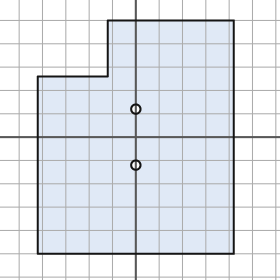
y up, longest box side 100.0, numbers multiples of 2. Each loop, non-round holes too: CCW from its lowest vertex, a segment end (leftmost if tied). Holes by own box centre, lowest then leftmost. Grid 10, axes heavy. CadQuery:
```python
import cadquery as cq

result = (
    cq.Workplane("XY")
    .moveTo(-42.0, -50.0)
    .lineTo(42.0, -50.0)
    .lineTo(42.0, 50.0)
    .lineTo(-12.0, 50.0)
    .lineTo(-12.0, 26.0)
    .lineTo(-42.0, 26.0)
    .close()
    .moveTo(0.0, -12.0)
    .circle(2.0)
    .moveTo(0.0, 12.0)
    .circle(2.0)
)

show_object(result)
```